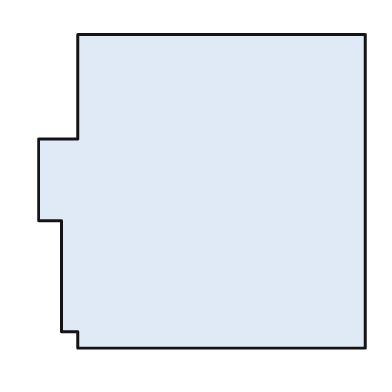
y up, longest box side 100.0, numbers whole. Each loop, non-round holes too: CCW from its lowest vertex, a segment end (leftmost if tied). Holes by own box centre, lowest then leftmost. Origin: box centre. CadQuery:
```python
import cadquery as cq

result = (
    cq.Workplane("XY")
    .moveTo(-38.0, -48.0)
    .lineTo(50.0, -48.0)
    .lineTo(50.0, 48.0)
    .lineTo(-38.0, 48.0)
    .lineTo(-38.0, 16.0)
    .lineTo(-50.0, 16.0)
    .lineTo(-50.0, -9.0)
    .lineTo(-43.0, -9.0)
    .lineTo(-43.0, -43.0)
    .lineTo(-38.0, -43.0)
    .close()
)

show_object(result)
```